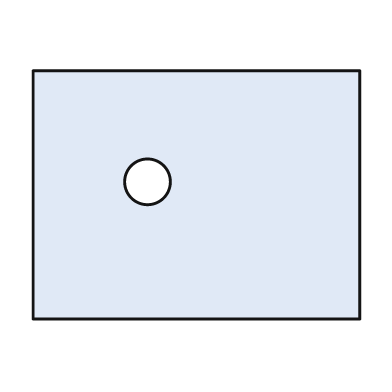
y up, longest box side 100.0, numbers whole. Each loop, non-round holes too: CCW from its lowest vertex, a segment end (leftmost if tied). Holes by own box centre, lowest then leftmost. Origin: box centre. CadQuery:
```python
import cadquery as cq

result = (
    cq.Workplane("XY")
    .moveTo(-50.0, -38.0)
    .lineTo(50.0, -38.0)
    .lineTo(50.0, 38.0)
    .lineTo(-50.0, 38.0)
    .close()
    .moveTo(-15.0, 4.0)
    .circle(7.0)
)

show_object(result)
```